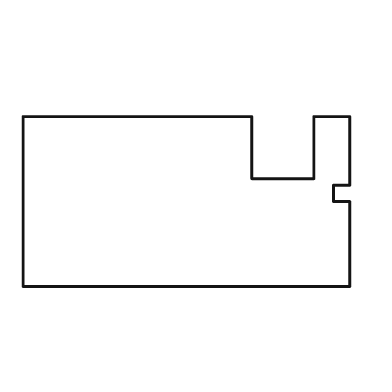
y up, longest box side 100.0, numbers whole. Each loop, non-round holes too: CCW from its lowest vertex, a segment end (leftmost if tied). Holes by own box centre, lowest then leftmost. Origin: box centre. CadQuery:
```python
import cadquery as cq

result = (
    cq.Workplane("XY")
    .moveTo(-50.0, -26.0)
    .lineTo(50.0, -26.0)
    .lineTo(50.0, 0.0)
    .lineTo(45.0, 0.0)
    .lineTo(45.0, 5.0)
    .lineTo(50.0, 5.0)
    .lineTo(50.0, 26.0)
    .lineTo(39.0, 26.0)
    .lineTo(39.0, 7.0)
    .lineTo(20.0, 7.0)
    .lineTo(20.0, 26.0)
    .lineTo(-50.0, 26.0)
    .close()
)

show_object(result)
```